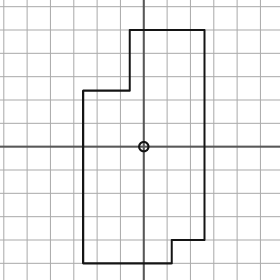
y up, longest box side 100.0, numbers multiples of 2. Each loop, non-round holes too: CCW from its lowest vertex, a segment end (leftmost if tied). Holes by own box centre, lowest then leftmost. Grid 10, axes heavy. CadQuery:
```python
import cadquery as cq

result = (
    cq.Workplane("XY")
    .moveTo(-26.0, -50.0)
    .lineTo(12.0, -50.0)
    .lineTo(12.0, -40.0)
    .lineTo(26.0, -40.0)
    .lineTo(26.0, 50.0)
    .lineTo(-6.0, 50.0)
    .lineTo(-6.0, 24.0)
    .lineTo(-26.0, 24.0)
    .close()
    .moveTo(0.0, 0.0)
    .circle(2.0)
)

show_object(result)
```